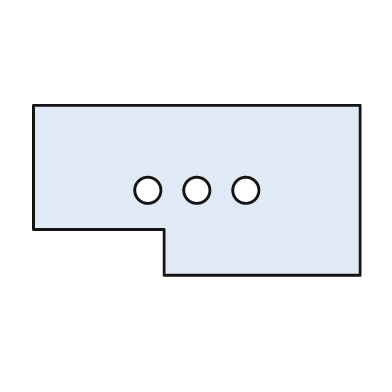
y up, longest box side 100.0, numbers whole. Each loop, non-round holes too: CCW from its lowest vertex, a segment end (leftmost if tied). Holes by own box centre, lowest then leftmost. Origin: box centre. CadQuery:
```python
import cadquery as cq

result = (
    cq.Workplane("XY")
    .moveTo(-10.0, -26.0)
    .lineTo(50.0, -26.0)
    .lineTo(50.0, 26.0)
    .lineTo(-50.0, 26.0)
    .lineTo(-50.0, -12.0)
    .lineTo(-10.0, -12.0)
    .close()
    .moveTo(-15.0, 0.0)
    .circle(4.0)
    .moveTo(0.0, 0.0)
    .circle(4.0)
    .moveTo(15.0, 0.0)
    .circle(4.0)
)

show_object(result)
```